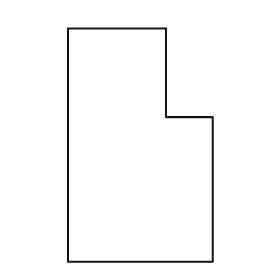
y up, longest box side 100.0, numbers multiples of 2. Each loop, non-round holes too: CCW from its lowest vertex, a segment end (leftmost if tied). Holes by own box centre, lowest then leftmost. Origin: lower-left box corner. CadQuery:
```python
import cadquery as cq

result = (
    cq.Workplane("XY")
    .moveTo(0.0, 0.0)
    .lineTo(62.0, 0.0)
    .lineTo(62.0, 62.0)
    .lineTo(42.0, 62.0)
    .lineTo(42.0, 100.0)
    .lineTo(0.0, 100.0)
    .close()
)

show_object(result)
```